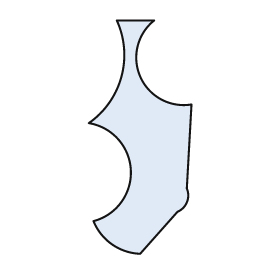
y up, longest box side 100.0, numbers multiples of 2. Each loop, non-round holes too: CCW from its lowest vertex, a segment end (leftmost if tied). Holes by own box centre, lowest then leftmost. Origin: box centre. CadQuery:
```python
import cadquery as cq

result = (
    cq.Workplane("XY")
    .moveTo(0.0, -50.0)
    .lineTo(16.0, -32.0)
    .threePointArc((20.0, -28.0), (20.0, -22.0))
    .lineTo(22.0, 14.0)
    .threePointArc((0.0, 26.0), (6.0, 50.0))
    .lineTo(-10.0, 50.0)
    .threePointArc((-8.0, 26.0), (-22.0, 6.0))
    .threePointArc((-4.0, -14.0), (-20.0, -36.0))
    .threePointArc((-12.0, -46.0), (0.0, -50.0))
    .close()
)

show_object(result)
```